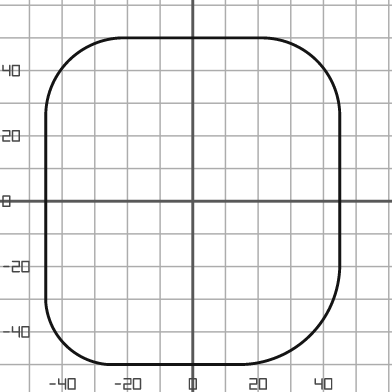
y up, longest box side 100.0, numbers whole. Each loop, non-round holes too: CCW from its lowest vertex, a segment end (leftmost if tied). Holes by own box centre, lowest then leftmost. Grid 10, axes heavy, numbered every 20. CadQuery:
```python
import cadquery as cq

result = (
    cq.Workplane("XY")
    .moveTo(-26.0, -50.0)
    .lineTo(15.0, -50.0)
    .threePointArc((36.0, -41.0), (45.0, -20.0))
    .lineTo(45.0, 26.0)
    .threePointArc((38.0, 43.0), (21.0, 50.0))
    .lineTo(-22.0, 50.0)
    .threePointArc((-38.0, 43.0), (-45.0, 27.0))
    .lineTo(-45.0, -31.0)
    .threePointArc((-39.0, -44.0), (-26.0, -50.0))
    .close()
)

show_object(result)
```